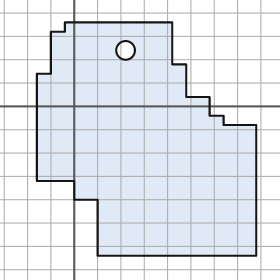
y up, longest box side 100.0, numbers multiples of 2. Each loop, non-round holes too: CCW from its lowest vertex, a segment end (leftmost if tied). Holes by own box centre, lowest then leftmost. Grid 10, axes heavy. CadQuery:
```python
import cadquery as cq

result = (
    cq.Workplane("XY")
    .moveTo(10.0, -64.0)
    .lineTo(78.0, -64.0)
    .lineTo(78.0, -8.0)
    .lineTo(64.0, -8.0)
    .lineTo(64.0, -4.0)
    .lineTo(58.0, -4.0)
    .lineTo(58.0, 4.0)
    .lineTo(48.0, 4.0)
    .lineTo(48.0, 18.0)
    .lineTo(42.0, 18.0)
    .lineTo(42.0, 36.0)
    .lineTo(-4.0, 36.0)
    .lineTo(-4.0, 32.0)
    .lineTo(-10.0, 32.0)
    .lineTo(-10.0, 14.0)
    .lineTo(-16.0, 14.0)
    .lineTo(-16.0, -32.0)
    .lineTo(0.0, -32.0)
    .lineTo(0.0, -40.0)
    .lineTo(10.0, -40.0)
    .close()
    .moveTo(22.0, 24.0)
    .circle(4.0)
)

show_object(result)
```